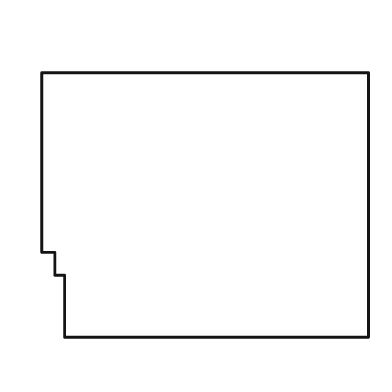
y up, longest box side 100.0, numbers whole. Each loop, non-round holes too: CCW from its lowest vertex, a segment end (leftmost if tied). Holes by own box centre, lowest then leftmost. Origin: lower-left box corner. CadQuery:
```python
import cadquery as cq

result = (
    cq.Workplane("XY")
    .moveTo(7.0, 0.0)
    .lineTo(100.0, 0.0)
    .lineTo(100.0, 81.0)
    .lineTo(0.0, 81.0)
    .lineTo(0.0, 26.0)
    .lineTo(4.0, 26.0)
    .lineTo(4.0, 19.0)
    .lineTo(7.0, 19.0)
    .close()
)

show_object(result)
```